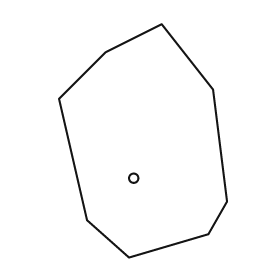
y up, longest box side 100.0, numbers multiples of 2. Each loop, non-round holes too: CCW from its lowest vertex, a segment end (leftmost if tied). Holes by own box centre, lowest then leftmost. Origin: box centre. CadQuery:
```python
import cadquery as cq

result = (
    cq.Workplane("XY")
    .moveTo(-6.0, -50.0)
    .lineTo(28.0, -40.0)
    .lineTo(36.0, -26.0)
    .lineTo(30.0, 22.0)
    .lineTo(8.0, 50.0)
    .lineTo(-16.0, 38.0)
    .lineTo(-36.0, 18.0)
    .lineTo(-24.0, -34.0)
    .close()
    .moveTo(-4.0, -16.0)
    .circle(2.0)
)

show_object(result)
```